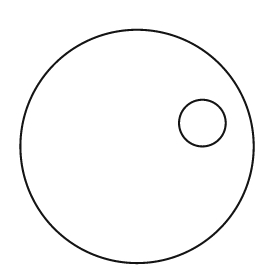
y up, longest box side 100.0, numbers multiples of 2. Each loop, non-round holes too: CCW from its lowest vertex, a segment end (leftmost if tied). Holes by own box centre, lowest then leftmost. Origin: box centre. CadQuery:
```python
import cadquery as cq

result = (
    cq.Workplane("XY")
    .moveTo(0.0, 0.0)
    .circle(50.0)
    .moveTo(28.0, 10.0)
    .circle(10.0)
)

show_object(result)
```